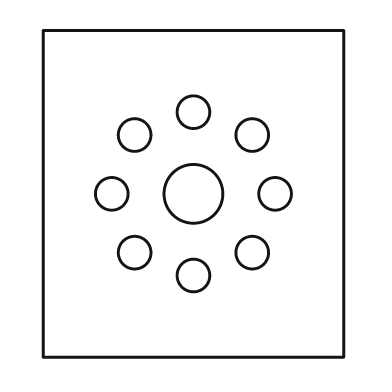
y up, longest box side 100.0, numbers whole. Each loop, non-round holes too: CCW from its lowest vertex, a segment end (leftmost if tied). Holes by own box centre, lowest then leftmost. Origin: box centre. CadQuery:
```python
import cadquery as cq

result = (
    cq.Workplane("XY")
    .moveTo(-46.0, -50.0)
    .lineTo(46.0, -50.0)
    .lineTo(46.0, 50.0)
    .lineTo(-46.0, 50.0)
    .close()
    .moveTo(0.0, -25.0)
    .circle(5.0)
    .moveTo(-18.0, -18.0)
    .circle(5.0)
    .moveTo(18.0, -18.0)
    .circle(5.0)
    .moveTo(-25.0, 0.0)
    .circle(5.0)
    .moveTo(0.0, 0.0)
    .circle(9.0)
    .moveTo(25.0, 0.0)
    .circle(5.0)
    .moveTo(-18.0, 18.0)
    .circle(5.0)
    .moveTo(18.0, 18.0)
    .circle(5.0)
    .moveTo(0.0, 25.0)
    .circle(5.0)
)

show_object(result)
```